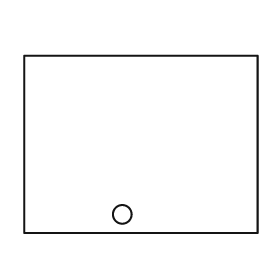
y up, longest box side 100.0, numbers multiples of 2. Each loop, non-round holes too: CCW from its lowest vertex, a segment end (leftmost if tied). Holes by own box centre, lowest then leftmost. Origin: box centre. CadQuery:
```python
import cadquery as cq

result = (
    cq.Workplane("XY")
    .moveTo(-50.0, -38.0)
    .lineTo(50.0, -38.0)
    .lineTo(50.0, 38.0)
    .lineTo(-50.0, 38.0)
    .close()
    .moveTo(-8.0, -30.0)
    .circle(4.0)
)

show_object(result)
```